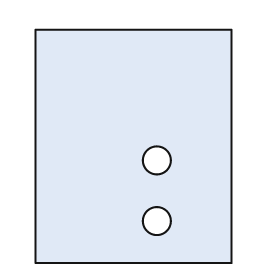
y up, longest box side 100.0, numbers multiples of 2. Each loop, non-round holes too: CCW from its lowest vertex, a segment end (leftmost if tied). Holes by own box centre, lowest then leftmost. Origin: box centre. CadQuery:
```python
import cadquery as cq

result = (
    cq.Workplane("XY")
    .moveTo(-42.0, -50.0)
    .lineTo(42.0, -50.0)
    .lineTo(42.0, 50.0)
    .lineTo(-42.0, 50.0)
    .close()
    .moveTo(10.0, -32.0)
    .circle(6.0)
    .moveTo(10.0, -6.0)
    .circle(6.0)
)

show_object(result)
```